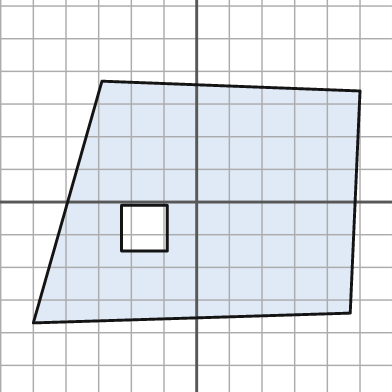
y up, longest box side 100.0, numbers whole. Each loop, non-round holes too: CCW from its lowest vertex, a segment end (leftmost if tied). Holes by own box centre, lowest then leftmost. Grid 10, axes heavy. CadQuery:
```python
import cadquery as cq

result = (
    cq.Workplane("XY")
    .moveTo(-50.0, -37.0)
    .lineTo(47.0, -34.0)
    .lineTo(50.0, 34.0)
    .lineTo(-29.0, 37.0)
    .close()
    .moveTo(-23.0, -15.0)
    .lineTo(-9.0, -15.0)
    .lineTo(-9.0, -1.0)
    .lineTo(-23.0, -1.0)
    .close()
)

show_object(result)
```